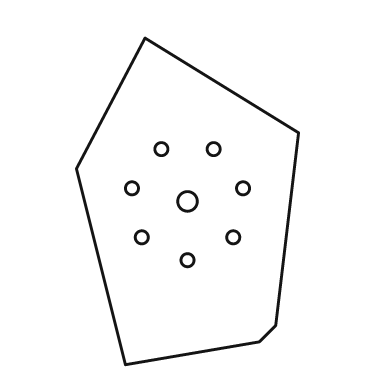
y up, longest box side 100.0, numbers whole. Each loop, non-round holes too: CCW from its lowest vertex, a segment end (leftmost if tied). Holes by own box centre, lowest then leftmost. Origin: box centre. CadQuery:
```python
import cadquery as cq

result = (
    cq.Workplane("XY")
    .moveTo(-19.0, -50.0)
    .lineTo(22.0, -43.0)
    .lineTo(27.0, -38.0)
    .lineTo(34.0, 21.0)
    .lineTo(-13.0, 50.0)
    .lineTo(-34.0, 10.0)
    .close()
    .moveTo(0.0, -18.0)
    .circle(2.0)
    .moveTo(-14.0, -11.0)
    .circle(2.0)
    .moveTo(14.0, -11.0)
    .circle(2.0)
    .moveTo(0.0, 0.0)
    .circle(3.0)
    .moveTo(-17.0, 4.0)
    .circle(2.0)
    .moveTo(17.0, 4.0)
    .circle(2.0)
    .moveTo(-8.0, 16.0)
    .circle(2.0)
    .moveTo(8.0, 16.0)
    .circle(2.0)
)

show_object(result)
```